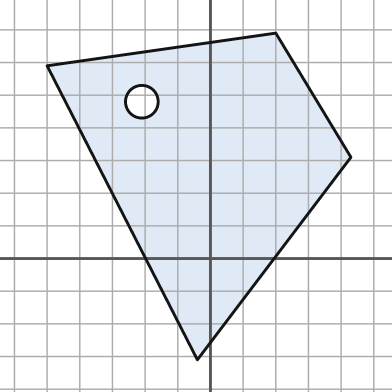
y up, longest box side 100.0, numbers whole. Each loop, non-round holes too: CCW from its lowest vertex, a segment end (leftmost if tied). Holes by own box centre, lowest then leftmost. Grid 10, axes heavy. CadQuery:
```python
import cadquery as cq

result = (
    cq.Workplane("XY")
    .moveTo(-4.0, -31.0)
    .lineTo(43.0, 31.0)
    .lineTo(20.0, 69.0)
    .lineTo(-50.0, 59.0)
    .close()
    .moveTo(-21.0, 48.0)
    .circle(5.0)
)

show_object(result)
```